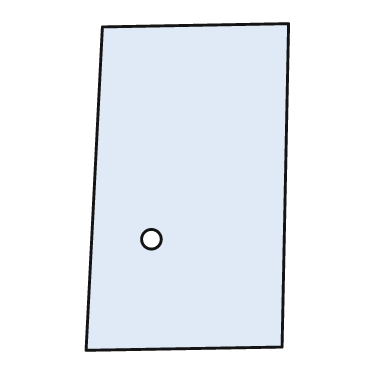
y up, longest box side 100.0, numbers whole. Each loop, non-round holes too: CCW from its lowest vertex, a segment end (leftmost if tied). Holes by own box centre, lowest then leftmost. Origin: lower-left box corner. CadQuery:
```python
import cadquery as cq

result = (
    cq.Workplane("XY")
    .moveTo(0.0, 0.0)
    .lineTo(60.0, 1.0)
    .lineTo(62.0, 100.0)
    .lineTo(5.0, 99.0)
    .close()
    .moveTo(20.0, 34.0)
    .circle(3.0)
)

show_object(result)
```